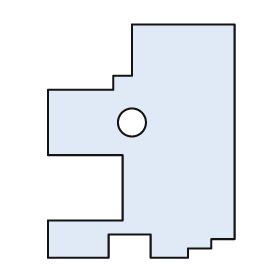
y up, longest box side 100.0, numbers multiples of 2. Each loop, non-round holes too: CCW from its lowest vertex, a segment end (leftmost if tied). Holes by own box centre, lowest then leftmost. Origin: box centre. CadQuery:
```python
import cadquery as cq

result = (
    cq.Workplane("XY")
    .moveTo(-40.0, -50.0)
    .lineTo(-14.0, -50.0)
    .lineTo(-14.0, -40.0)
    .lineTo(4.0, -40.0)
    .lineTo(4.0, -50.0)
    .lineTo(20.0, -50.0)
    .lineTo(20.0, -46.0)
    .lineTo(30.0, -46.0)
    .lineTo(30.0, -42.0)
    .lineTo(40.0, -42.0)
    .lineTo(40.0, 50.0)
    .lineTo(-4.0, 50.0)
    .lineTo(-4.0, 28.0)
    .lineTo(-12.0, 28.0)
    .lineTo(-12.0, 22.0)
    .lineTo(-40.0, 22.0)
    .lineTo(-40.0, -6.0)
    .lineTo(-8.0, -6.0)
    .lineTo(-8.0, -34.0)
    .lineTo(-40.0, -34.0)
    .close()
    .moveTo(-4.0, 8.0)
    .circle(6.0)
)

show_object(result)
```